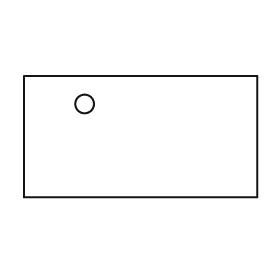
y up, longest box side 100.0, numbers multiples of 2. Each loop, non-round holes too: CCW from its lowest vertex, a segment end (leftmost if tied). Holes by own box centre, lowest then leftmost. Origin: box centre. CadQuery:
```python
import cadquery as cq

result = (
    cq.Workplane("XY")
    .moveTo(-50.0, -26.0)
    .lineTo(50.0, -26.0)
    .lineTo(50.0, 26.0)
    .lineTo(-50.0, 26.0)
    .close()
    .moveTo(-24.0, 14.0)
    .circle(4.0)
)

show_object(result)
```